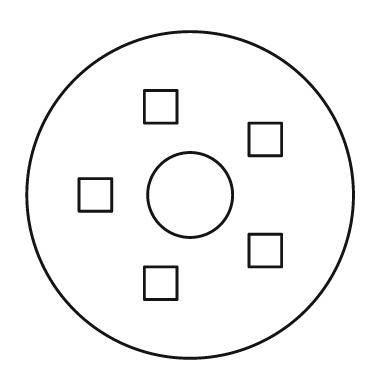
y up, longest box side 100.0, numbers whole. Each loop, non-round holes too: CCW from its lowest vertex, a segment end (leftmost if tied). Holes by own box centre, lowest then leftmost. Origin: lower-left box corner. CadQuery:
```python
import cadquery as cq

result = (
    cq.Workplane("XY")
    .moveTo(50.0, 50.0)
    .circle(50.0)
    .moveTo(36.0, 18.0)
    .lineTo(46.0, 18.0)
    .lineTo(46.0, 28.0)
    .lineTo(36.0, 28.0)
    .close()
    .moveTo(68.0, 28.0)
    .lineTo(78.0, 28.0)
    .lineTo(78.0, 38.0)
    .lineTo(68.0, 38.0)
    .close()
    .moveTo(16.0, 45.0)
    .lineTo(26.0, 45.0)
    .lineTo(26.0, 55.0)
    .lineTo(16.0, 55.0)
    .close()
    .moveTo(50.0, 50.0)
    .circle(13.0)
    .moveTo(68.0, 62.0)
    .lineTo(78.0, 62.0)
    .lineTo(78.0, 72.0)
    .lineTo(68.0, 72.0)
    .close()
    .moveTo(36.0, 72.0)
    .lineTo(46.0, 72.0)
    .lineTo(46.0, 82.0)
    .lineTo(36.0, 82.0)
    .close()
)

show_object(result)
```